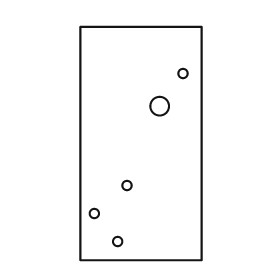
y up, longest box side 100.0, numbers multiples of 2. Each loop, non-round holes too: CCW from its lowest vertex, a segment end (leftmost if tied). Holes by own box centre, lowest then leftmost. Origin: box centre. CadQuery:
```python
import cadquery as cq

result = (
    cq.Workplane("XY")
    .moveTo(-26.0, -50.0)
    .lineTo(26.0, -50.0)
    .lineTo(26.0, 50.0)
    .lineTo(-26.0, 50.0)
    .close()
    .moveTo(-10.0, -42.0)
    .circle(2.0)
    .moveTo(-20.0, -30.0)
    .circle(2.0)
    .moveTo(-6.0, -18.0)
    .circle(2.0)
    .moveTo(8.0, 16.0)
    .circle(4.0)
    .moveTo(18.0, 30.0)
    .circle(2.0)
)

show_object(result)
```